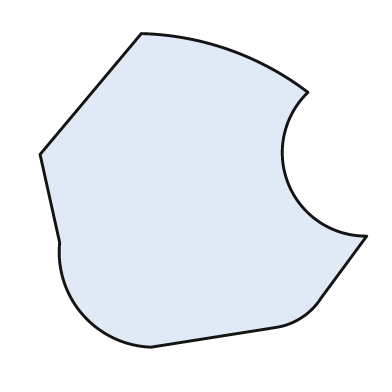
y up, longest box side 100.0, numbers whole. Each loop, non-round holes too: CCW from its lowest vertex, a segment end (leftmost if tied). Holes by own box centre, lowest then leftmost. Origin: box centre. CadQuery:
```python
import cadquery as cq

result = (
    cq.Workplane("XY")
    .moveTo(-16.0, -48.0)
    .lineTo(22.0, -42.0)
    .threePointArc((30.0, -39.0), (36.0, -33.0))
    .lineTo(50.0, -14.0)
    .threePointArc((26.0, 2.0), (32.0, 30.0))
    .threePointArc((8.0, 43.0), (-19.0, 48.0))
    .lineTo(-50.0, 11.0)
    .lineTo(-44.0, -16.0)
    .threePointArc((-37.0, -38.0), (-16.0, -48.0))
    .close()
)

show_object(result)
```